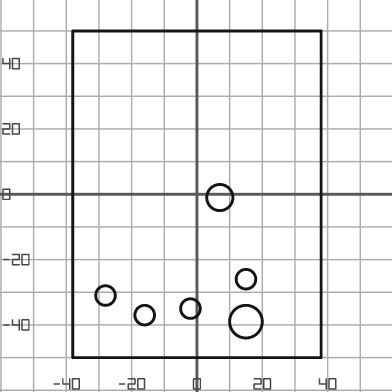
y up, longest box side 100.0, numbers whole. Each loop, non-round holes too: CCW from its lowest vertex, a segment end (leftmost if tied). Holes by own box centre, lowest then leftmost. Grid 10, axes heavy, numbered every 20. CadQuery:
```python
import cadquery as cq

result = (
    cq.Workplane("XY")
    .moveTo(-38.0, -50.0)
    .lineTo(38.0, -50.0)
    .lineTo(38.0, 50.0)
    .lineTo(-38.0, 50.0)
    .close()
    .moveTo(15.0, -39.0)
    .circle(5.0)
    .moveTo(-16.0, -37.0)
    .circle(3.0)
    .moveTo(-2.0, -35.0)
    .circle(3.0)
    .moveTo(-28.0, -31.0)
    .circle(3.0)
    .moveTo(15.0, -26.0)
    .circle(3.0)
    .moveTo(7.0, -1.0)
    .circle(4.0)
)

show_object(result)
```